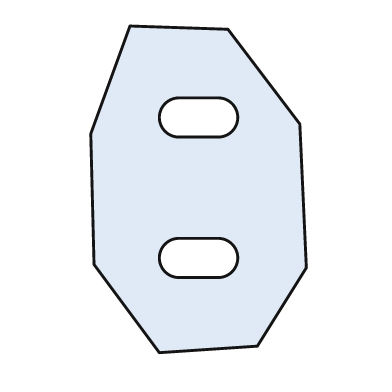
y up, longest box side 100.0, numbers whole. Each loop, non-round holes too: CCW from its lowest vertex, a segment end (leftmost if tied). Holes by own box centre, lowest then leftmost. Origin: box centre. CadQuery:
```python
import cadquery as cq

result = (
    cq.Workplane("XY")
    .moveTo(-12.0, -50.0)
    .lineTo(18.0, -48.0)
    .lineTo(33.0, -24.0)
    .lineTo(31.0, 20.0)
    .lineTo(9.0, 49.0)
    .lineTo(-21.0, 50.0)
    .lineTo(-33.0, 17.0)
    .lineTo(-32.0, -23.0)
    .close()
    .moveTo(-6.0, -27.0)
    .lineTo(6.0, -27.0)
    .threePointArc((12.0, -21.0), (6.0, -15.0))
    .lineTo(-6.0, -15.0)
    .threePointArc((-12.0, -21.0), (-6.0, -27.0))
    .close()
    .moveTo(-6.0, 16.0)
    .lineTo(6.0, 16.0)
    .threePointArc((12.0, 22.0), (6.0, 28.0))
    .lineTo(-6.0, 28.0)
    .threePointArc((-12.0, 22.0), (-6.0, 16.0))
    .close()
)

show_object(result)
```